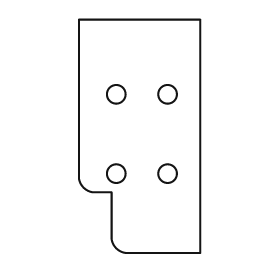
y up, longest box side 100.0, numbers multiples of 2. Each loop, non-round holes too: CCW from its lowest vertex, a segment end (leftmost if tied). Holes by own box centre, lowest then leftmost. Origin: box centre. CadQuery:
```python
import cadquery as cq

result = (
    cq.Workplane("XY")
    .moveTo(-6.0, -50.0)
    .lineTo(26.0, -50.0)
    .lineTo(26.0, 50.0)
    .lineTo(-26.0, 50.0)
    .lineTo(-26.0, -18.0)
    .threePointArc((-24.0, -22.0), (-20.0, -24.0))
    .lineTo(-12.0, -24.0)
    .lineTo(-12.0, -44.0)
    .threePointArc((-10.0, -48.0), (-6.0, -50.0))
    .close()
    .moveTo(-10.0, -16.0)
    .circle(4.0)
    .moveTo(12.0, -16.0)
    .circle(4.0)
    .moveTo(-10.0, 18.0)
    .circle(4.0)
    .moveTo(12.0, 18.0)
    .circle(4.0)
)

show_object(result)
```